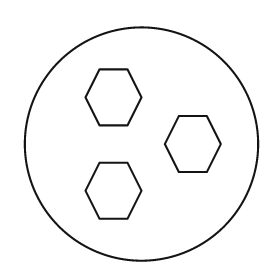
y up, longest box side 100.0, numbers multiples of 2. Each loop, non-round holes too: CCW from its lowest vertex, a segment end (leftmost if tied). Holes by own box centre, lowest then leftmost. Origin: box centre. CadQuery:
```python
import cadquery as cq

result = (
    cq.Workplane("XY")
    .moveTo(0.0, 0.0)
    .circle(50.0)
    .moveTo(-18.0, -32.0)
    .lineTo(-6.0, -32.0)
    .lineTo(0.0, -20.0)
    .lineTo(-6.0, -8.0)
    .lineTo(-18.0, -8.0)
    .lineTo(-24.0, -20.0)
    .close()
    .moveTo(16.0, -12.0)
    .lineTo(28.0, -12.0)
    .lineTo(34.0, 0.0)
    .lineTo(28.0, 12.0)
    .lineTo(16.0, 12.0)
    .lineTo(10.0, 0.0)
    .close()
    .moveTo(-18.0, 8.0)
    .lineTo(-6.0, 8.0)
    .lineTo(0.0, 20.0)
    .lineTo(-6.0, 32.0)
    .lineTo(-18.0, 32.0)
    .lineTo(-24.0, 20.0)
    .close()
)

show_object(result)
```